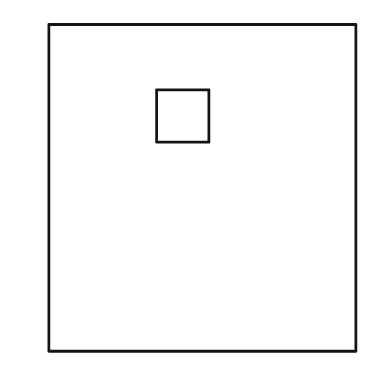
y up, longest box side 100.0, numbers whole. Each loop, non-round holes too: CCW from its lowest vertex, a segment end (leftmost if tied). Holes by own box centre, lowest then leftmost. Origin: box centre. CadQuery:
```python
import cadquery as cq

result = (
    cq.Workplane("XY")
    .moveTo(-47.0, -50.0)
    .lineTo(47.0, -50.0)
    .lineTo(47.0, 50.0)
    .lineTo(-47.0, 50.0)
    .close()
    .moveTo(-14.0, 14.0)
    .lineTo(2.0, 14.0)
    .lineTo(2.0, 30.0)
    .lineTo(-14.0, 30.0)
    .close()
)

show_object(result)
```